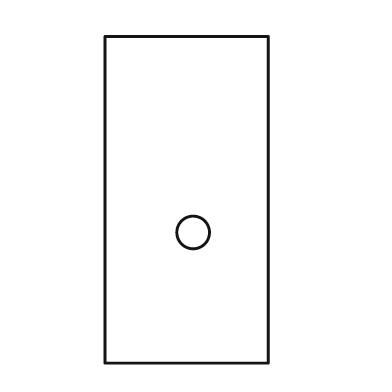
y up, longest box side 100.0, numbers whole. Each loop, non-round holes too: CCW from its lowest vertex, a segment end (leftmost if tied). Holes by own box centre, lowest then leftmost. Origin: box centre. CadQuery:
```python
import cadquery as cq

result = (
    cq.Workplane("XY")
    .moveTo(-25.0, -50.0)
    .lineTo(25.0, -50.0)
    .lineTo(25.0, 50.0)
    .lineTo(-25.0, 50.0)
    .close()
    .moveTo(2.0, -10.0)
    .circle(5.0)
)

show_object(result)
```